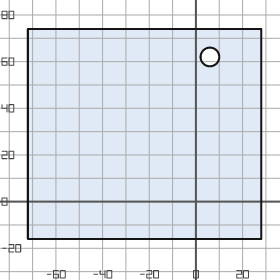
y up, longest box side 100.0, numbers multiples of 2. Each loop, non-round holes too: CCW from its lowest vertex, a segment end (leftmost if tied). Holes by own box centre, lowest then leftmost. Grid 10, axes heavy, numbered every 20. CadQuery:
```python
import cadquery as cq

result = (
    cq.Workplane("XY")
    .moveTo(-72.0, -16.0)
    .lineTo(28.0, -16.0)
    .lineTo(28.0, 74.0)
    .lineTo(-72.0, 74.0)
    .close()
    .moveTo(6.0, 62.0)
    .circle(4.0)
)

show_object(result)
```